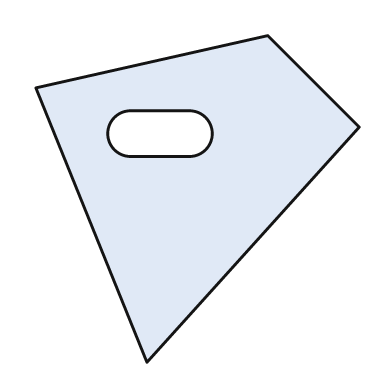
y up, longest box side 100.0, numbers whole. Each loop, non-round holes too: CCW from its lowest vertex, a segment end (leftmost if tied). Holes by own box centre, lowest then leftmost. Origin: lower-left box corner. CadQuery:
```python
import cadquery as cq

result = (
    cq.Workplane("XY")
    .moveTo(34.0, 0.0)
    .lineTo(99.0, 72.0)
    .lineTo(71.0, 100.0)
    .lineTo(0.0, 84.0)
    .close()
    .moveTo(29.0, 63.0)
    .lineTo(47.0, 63.0)
    .threePointArc((54.0, 70.0), (47.0, 77.0))
    .lineTo(29.0, 77.0)
    .threePointArc((22.0, 70.0), (29.0, 63.0))
    .close()
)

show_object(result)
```